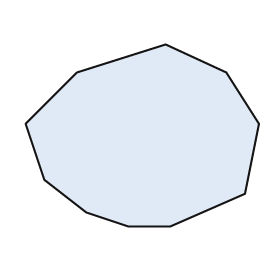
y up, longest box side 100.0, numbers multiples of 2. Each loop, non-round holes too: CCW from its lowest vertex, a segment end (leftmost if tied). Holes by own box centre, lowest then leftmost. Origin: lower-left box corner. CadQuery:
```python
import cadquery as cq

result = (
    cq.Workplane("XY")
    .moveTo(44.0, 0.0)
    .lineTo(62.0, 0.0)
    .lineTo(94.0, 14.0)
    .lineTo(100.0, 44.0)
    .lineTo(86.0, 66.0)
    .lineTo(60.0, 78.0)
    .lineTo(22.0, 66.0)
    .lineTo(0.0, 44.0)
    .lineTo(8.0, 20.0)
    .lineTo(26.0, 6.0)
    .close()
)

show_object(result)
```